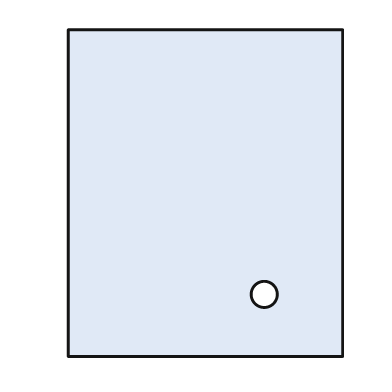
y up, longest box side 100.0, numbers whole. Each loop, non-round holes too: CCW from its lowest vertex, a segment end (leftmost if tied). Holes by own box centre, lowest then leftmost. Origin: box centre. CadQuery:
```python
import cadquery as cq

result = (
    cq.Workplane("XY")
    .moveTo(-42.0, -50.0)
    .lineTo(42.0, -50.0)
    .lineTo(42.0, 50.0)
    .lineTo(-42.0, 50.0)
    .close()
    .moveTo(18.0, -31.0)
    .circle(4.0)
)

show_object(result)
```